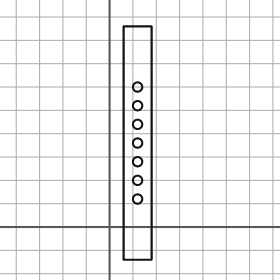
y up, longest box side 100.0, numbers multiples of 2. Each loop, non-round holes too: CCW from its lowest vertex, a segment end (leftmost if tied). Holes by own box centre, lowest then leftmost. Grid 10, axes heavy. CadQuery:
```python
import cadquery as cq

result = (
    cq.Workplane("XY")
    .moveTo(6.0, -14.0)
    .lineTo(18.0, -14.0)
    .lineTo(18.0, 86.0)
    .lineTo(6.0, 86.0)
    .close()
    .moveTo(12.0, 12.0)
    .circle(2.0)
    .moveTo(12.0, 20.0)
    .circle(2.0)
    .moveTo(12.0, 28.0)
    .circle(2.0)
    .moveTo(12.0, 36.0)
    .circle(2.0)
    .moveTo(12.0, 44.0)
    .circle(2.0)
    .moveTo(12.0, 52.0)
    .circle(2.0)
    .moveTo(12.0, 60.0)
    .circle(2.0)
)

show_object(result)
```